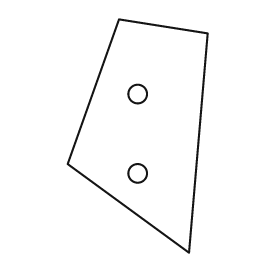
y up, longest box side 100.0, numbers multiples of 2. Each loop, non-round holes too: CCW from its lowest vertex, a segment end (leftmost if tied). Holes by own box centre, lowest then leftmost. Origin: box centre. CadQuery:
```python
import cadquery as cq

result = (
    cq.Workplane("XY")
    .moveTo(22.0, -50.0)
    .lineTo(30.0, 44.0)
    .lineTo(-8.0, 50.0)
    .lineTo(-30.0, -12.0)
    .close()
    .moveTo(0.0, -16.0)
    .circle(4.0)
    .moveTo(0.0, 18.0)
    .circle(4.0)
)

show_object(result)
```